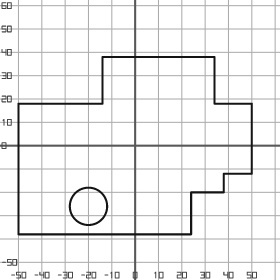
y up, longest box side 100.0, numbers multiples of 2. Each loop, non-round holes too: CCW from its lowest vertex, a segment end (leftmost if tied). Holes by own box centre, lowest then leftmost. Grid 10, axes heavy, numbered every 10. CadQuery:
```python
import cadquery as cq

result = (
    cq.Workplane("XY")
    .moveTo(-50.0, -38.0)
    .lineTo(24.0, -38.0)
    .lineTo(24.0, -20.0)
    .lineTo(38.0, -20.0)
    .lineTo(38.0, -12.0)
    .lineTo(50.0, -12.0)
    .lineTo(50.0, 18.0)
    .lineTo(34.0, 18.0)
    .lineTo(34.0, 38.0)
    .lineTo(-14.0, 38.0)
    .lineTo(-14.0, 18.0)
    .lineTo(-50.0, 18.0)
    .close()
    .moveTo(-20.0, -26.0)
    .circle(8.0)
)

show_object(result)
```